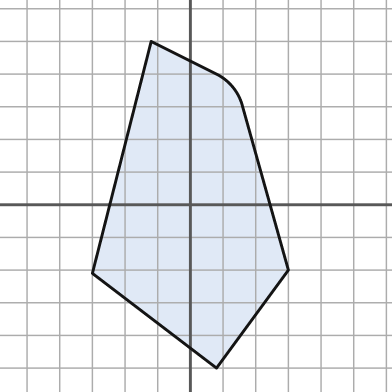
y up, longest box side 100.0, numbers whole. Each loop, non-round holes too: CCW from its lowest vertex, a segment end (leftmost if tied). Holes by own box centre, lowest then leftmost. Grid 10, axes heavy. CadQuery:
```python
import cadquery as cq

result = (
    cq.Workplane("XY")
    .moveTo(8.0, -50.0)
    .lineTo(30.0, -20.0)
    .lineTo(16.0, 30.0)
    .threePointArc((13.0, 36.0), (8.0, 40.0))
    .lineTo(-12.0, 50.0)
    .lineTo(-30.0, -21.0)
    .close()
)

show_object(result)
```